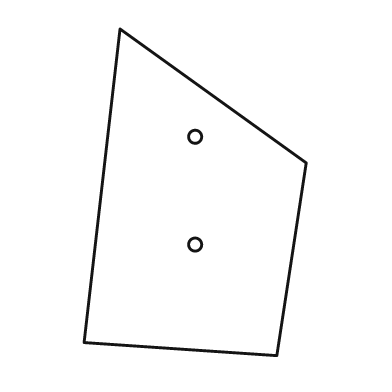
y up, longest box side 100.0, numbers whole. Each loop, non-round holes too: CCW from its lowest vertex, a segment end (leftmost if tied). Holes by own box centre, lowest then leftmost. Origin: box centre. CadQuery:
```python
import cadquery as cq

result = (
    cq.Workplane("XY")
    .moveTo(25.0, -50.0)
    .lineTo(34.0, 9.0)
    .lineTo(-23.0, 50.0)
    .lineTo(-34.0, -46.0)
    .close()
    .moveTo(0.0, -16.0)
    .circle(2.0)
    .moveTo(0.0, 17.0)
    .circle(2.0)
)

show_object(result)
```